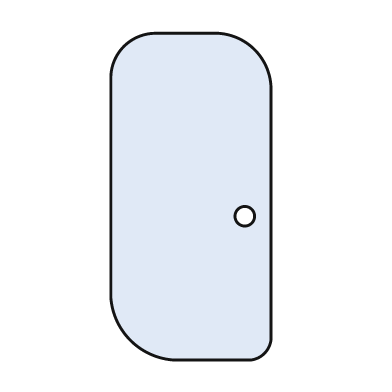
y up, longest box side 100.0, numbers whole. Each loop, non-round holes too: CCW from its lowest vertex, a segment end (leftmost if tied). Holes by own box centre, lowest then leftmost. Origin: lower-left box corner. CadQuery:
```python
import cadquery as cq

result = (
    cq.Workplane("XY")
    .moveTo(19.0, 0.0)
    .lineTo(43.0, 0.0)
    .threePointArc((47.0, 2.0), (49.0, 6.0))
    .lineTo(49.0, 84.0)
    .threePointArc((44.0, 95.0), (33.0, 100.0))
    .lineTo(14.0, 100.0)
    .threePointArc((4.0, 96.0), (0.0, 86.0))
    .lineTo(0.0, 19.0)
    .threePointArc((6.0, 6.0), (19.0, 0.0))
    .close()
    .moveTo(41.0, 44.0)
    .circle(3.0)
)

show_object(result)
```